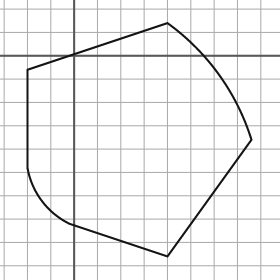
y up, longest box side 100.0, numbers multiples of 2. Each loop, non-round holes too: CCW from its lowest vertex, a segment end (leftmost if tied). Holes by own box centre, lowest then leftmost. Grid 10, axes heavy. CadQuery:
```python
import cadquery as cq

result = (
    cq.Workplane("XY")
    .moveTo(40.0, -86.0)
    .lineTo(76.0, -36.0)
    .threePointArc((62.0, -8.0), (40.0, 14.0))
    .lineTo(-20.0, -6.0)
    .lineTo(-20.0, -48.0)
    .threePointArc((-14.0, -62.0), (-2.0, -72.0))
    .close()
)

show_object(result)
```